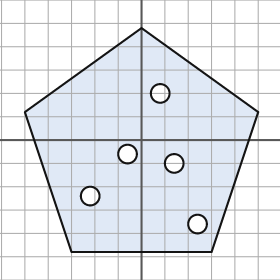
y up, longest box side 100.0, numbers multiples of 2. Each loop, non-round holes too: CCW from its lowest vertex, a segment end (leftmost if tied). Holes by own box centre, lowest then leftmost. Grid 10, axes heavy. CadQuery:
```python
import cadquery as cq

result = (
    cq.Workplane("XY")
    .moveTo(-30.0, -48.0)
    .lineTo(30.0, -48.0)
    .lineTo(50.0, 12.0)
    .lineTo(0.0, 48.0)
    .lineTo(-50.0, 12.0)
    .close()
    .moveTo(24.0, -36.0)
    .circle(4.0)
    .moveTo(-22.0, -24.0)
    .circle(4.0)
    .moveTo(14.0, -10.0)
    .circle(4.0)
    .moveTo(-6.0, -6.0)
    .circle(4.0)
    .moveTo(8.0, 20.0)
    .circle(4.0)
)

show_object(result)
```